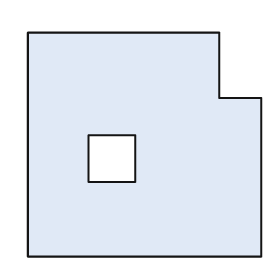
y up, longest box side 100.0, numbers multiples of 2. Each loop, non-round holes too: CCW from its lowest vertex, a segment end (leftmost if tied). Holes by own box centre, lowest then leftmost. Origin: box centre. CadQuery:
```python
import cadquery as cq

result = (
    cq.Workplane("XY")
    .moveTo(-50.0, -48.0)
    .lineTo(50.0, -48.0)
    .lineTo(50.0, 20.0)
    .lineTo(32.0, 20.0)
    .lineTo(32.0, 48.0)
    .lineTo(-50.0, 48.0)
    .close()
    .moveTo(-24.0, -16.0)
    .lineTo(-4.0, -16.0)
    .lineTo(-4.0, 4.0)
    .lineTo(-24.0, 4.0)
    .close()
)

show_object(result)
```